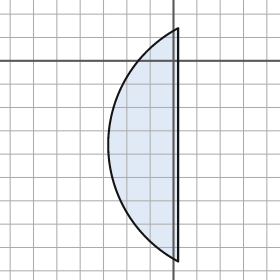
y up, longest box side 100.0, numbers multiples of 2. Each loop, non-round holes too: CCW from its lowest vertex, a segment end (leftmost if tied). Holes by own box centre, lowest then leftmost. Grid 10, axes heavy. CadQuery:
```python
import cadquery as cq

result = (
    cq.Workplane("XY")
    .moveTo(2.0, -86.0)
    .lineTo(2.0, 14.0)
    .threePointArc((-28.0, -36.0), (2.0, -86.0))
    .close()
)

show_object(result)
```